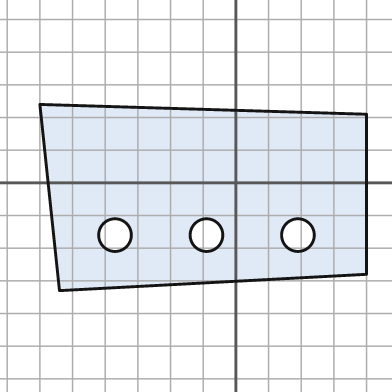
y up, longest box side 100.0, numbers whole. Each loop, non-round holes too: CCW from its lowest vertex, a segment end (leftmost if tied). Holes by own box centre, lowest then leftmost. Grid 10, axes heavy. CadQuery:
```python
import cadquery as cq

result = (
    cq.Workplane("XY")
    .moveTo(-54.0, -33.0)
    .lineTo(40.0, -28.0)
    .lineTo(40.0, 21.0)
    .lineTo(-60.0, 24.0)
    .close()
    .moveTo(-37.0, -16.0)
    .circle(5.0)
    .moveTo(-9.0, -16.0)
    .circle(5.0)
    .moveTo(19.0, -16.0)
    .circle(5.0)
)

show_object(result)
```